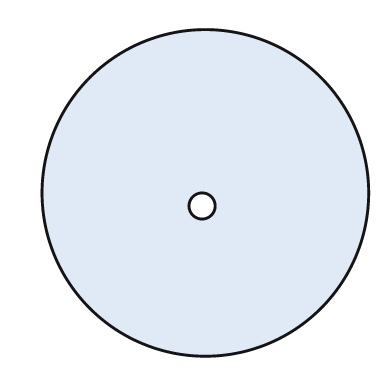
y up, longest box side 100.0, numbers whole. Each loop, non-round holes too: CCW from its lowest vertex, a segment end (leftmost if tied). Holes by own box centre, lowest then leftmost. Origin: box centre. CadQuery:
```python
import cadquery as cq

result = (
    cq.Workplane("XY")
    .moveTo(0.0, 0.0)
    .circle(50.0)
    .moveTo(-1.0, -4.0)
    .circle(4.0)
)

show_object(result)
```